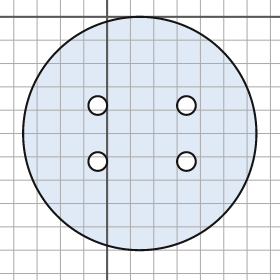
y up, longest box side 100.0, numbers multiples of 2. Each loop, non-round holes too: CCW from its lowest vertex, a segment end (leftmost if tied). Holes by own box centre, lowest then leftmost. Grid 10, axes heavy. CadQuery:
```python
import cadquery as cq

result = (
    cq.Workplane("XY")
    .moveTo(14.0, -50.0)
    .circle(50.0)
    .moveTo(-4.0, -62.0)
    .circle(4.0)
    .moveTo(34.0, -62.0)
    .circle(4.0)
    .moveTo(-4.0, -38.0)
    .circle(4.0)
    .moveTo(34.0, -38.0)
    .circle(4.0)
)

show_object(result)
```